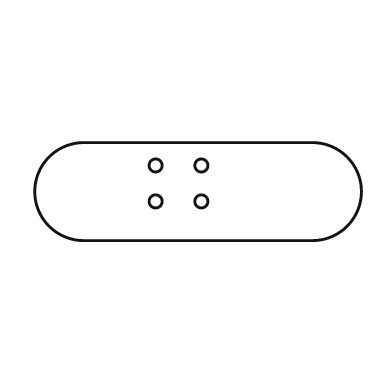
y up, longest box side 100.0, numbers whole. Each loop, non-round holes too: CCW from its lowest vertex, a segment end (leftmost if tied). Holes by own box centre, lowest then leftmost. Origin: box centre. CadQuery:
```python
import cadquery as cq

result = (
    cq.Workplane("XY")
    .moveTo(-35.0, -15.0)
    .lineTo(35.0, -15.0)
    .threePointArc((50.0, 0.0), (35.0, 15.0))
    .lineTo(-35.0, 15.0)
    .threePointArc((-50.0, 0.0), (-35.0, -15.0))
    .close()
    .moveTo(-13.0, -3.0)
    .circle(2.0)
    .moveTo(1.0, -3.0)
    .circle(2.0)
    .moveTo(-13.0, 8.0)
    .circle(2.0)
    .moveTo(1.0, 8.0)
    .circle(2.0)
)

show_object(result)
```